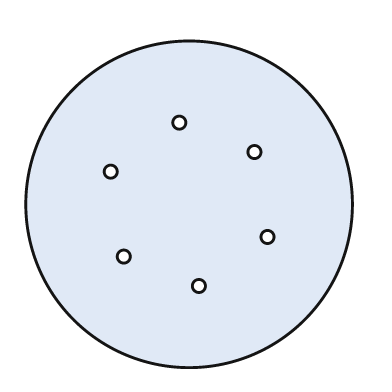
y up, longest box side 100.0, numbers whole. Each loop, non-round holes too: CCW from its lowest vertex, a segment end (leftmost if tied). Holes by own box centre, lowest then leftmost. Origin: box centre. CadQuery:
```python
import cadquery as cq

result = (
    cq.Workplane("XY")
    .moveTo(0.0, 0.0)
    .circle(50.0)
    .moveTo(3.0, -25.0)
    .circle(2.0)
    .moveTo(-20.0, -16.0)
    .circle(2.0)
    .moveTo(24.0, -10.0)
    .circle(2.0)
    .moveTo(-24.0, 10.0)
    .circle(2.0)
    .moveTo(20.0, 16.0)
    .circle(2.0)
    .moveTo(-3.0, 25.0)
    .circle(2.0)
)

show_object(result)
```